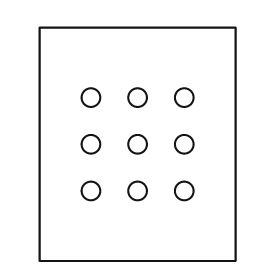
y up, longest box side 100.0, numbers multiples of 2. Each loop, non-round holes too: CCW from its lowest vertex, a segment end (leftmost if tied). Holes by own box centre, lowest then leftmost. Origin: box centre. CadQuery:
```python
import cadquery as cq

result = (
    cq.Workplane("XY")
    .moveTo(-42.0, -50.0)
    .lineTo(42.0, -50.0)
    .lineTo(42.0, 50.0)
    .lineTo(-42.0, 50.0)
    .close()
    .moveTo(-20.0, -20.0)
    .circle(4.0)
    .moveTo(0.0, -20.0)
    .circle(4.0)
    .moveTo(20.0, -20.0)
    .circle(4.0)
    .moveTo(-20.0, 0.0)
    .circle(4.0)
    .moveTo(0.0, 0.0)
    .circle(4.0)
    .moveTo(20.0, 0.0)
    .circle(4.0)
    .moveTo(-20.0, 20.0)
    .circle(4.0)
    .moveTo(0.0, 20.0)
    .circle(4.0)
    .moveTo(20.0, 20.0)
    .circle(4.0)
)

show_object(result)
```